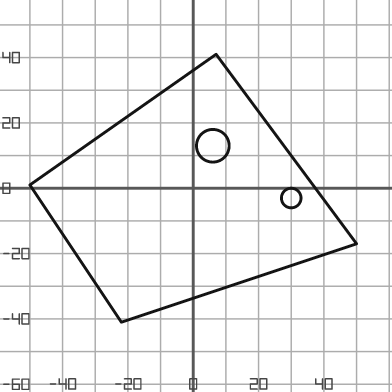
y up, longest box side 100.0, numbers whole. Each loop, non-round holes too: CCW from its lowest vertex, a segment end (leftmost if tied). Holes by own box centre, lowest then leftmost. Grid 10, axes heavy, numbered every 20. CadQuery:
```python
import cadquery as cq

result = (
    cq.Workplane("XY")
    .moveTo(-22.0, -41.0)
    .lineTo(50.0, -17.0)
    .lineTo(7.0, 41.0)
    .lineTo(-50.0, 1.0)
    .close()
    .moveTo(30.0, -3.0)
    .circle(3.0)
    .moveTo(6.0, 13.0)
    .circle(5.0)
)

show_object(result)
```